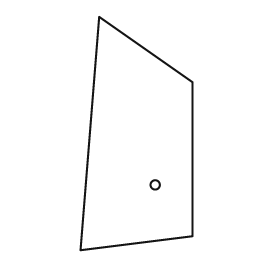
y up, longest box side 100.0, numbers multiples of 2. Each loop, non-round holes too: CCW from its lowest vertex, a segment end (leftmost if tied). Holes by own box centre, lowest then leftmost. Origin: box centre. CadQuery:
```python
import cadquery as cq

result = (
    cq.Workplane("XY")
    .moveTo(-24.0, -50.0)
    .lineTo(24.0, -44.0)
    .lineTo(24.0, 22.0)
    .lineTo(-16.0, 50.0)
    .close()
    .moveTo(8.0, -22.0)
    .circle(2.0)
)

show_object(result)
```